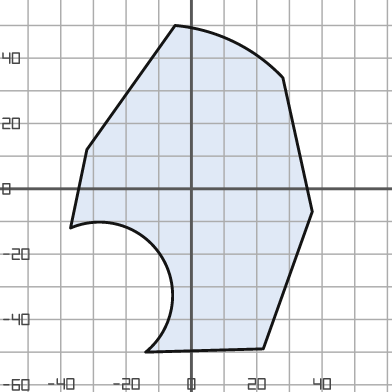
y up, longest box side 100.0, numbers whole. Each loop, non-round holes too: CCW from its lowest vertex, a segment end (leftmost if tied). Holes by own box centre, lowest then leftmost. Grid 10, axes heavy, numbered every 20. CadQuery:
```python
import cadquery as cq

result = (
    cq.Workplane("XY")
    .moveTo(-14.0, -50.0)
    .lineTo(22.0, -49.0)
    .lineTo(37.0, -7.0)
    .lineTo(28.0, 34.0)
    .threePointArc((13.0, 45.0), (-5.0, 50.0))
    .lineTo(-32.0, 12.0)
    .lineTo(-37.0, -12.0)
    .threePointArc((-9.0, -21.0), (-14.0, -50.0))
    .close()
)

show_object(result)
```